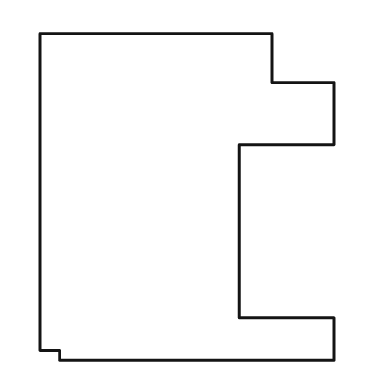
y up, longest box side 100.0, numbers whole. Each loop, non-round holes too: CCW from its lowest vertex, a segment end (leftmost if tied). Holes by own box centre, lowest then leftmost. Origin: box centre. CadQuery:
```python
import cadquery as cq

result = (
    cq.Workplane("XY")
    .moveTo(-39.0, -50.0)
    .lineTo(45.0, -50.0)
    .lineTo(45.0, -37.0)
    .lineTo(16.0, -37.0)
    .lineTo(16.0, 16.0)
    .lineTo(45.0, 16.0)
    .lineTo(45.0, 35.0)
    .lineTo(26.0, 35.0)
    .lineTo(26.0, 50.0)
    .lineTo(-45.0, 50.0)
    .lineTo(-45.0, -47.0)
    .lineTo(-39.0, -47.0)
    .close()
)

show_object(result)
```